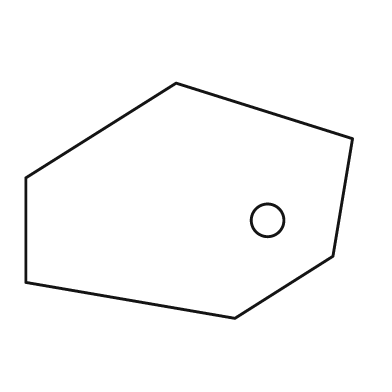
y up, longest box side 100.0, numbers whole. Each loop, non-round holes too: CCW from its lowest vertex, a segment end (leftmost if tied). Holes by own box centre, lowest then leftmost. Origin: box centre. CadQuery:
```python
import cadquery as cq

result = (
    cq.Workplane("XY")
    .moveTo(14.0, -36.0)
    .lineTo(44.0, -17.0)
    .lineTo(50.0, 19.0)
    .lineTo(-4.0, 36.0)
    .lineTo(-50.0, 7.0)
    .lineTo(-50.0, -25.0)
    .close()
    .moveTo(24.0, -6.0)
    .circle(5.0)
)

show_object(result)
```